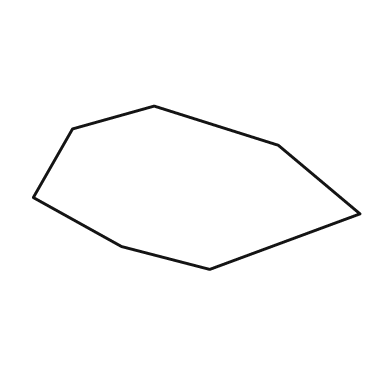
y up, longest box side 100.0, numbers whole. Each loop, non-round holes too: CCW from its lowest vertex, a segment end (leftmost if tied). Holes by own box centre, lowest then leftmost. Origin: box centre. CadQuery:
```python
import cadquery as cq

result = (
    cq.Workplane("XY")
    .moveTo(4.0, -25.0)
    .lineTo(50.0, -8.0)
    .lineTo(25.0, 13.0)
    .lineTo(-13.0, 25.0)
    .lineTo(-38.0, 18.0)
    .lineTo(-50.0, -3.0)
    .lineTo(-23.0, -18.0)
    .close()
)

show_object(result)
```